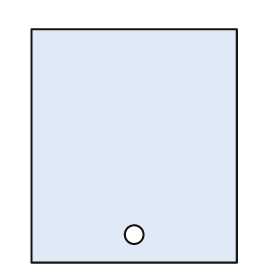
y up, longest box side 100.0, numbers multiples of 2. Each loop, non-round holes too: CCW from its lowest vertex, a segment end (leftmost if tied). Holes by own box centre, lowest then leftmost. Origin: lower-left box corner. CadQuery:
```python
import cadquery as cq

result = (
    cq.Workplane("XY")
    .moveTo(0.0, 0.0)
    .lineTo(88.0, 0.0)
    .lineTo(88.0, 100.0)
    .lineTo(0.0, 100.0)
    .close()
    .moveTo(44.0, 12.0)
    .circle(4.0)
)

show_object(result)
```